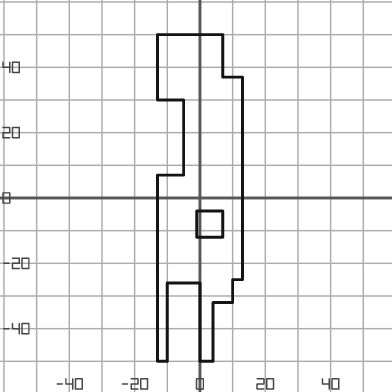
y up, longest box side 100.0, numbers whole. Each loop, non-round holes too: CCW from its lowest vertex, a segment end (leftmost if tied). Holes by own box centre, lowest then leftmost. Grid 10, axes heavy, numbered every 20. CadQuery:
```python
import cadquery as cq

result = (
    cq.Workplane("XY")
    .moveTo(-13.0, -50.0)
    .lineTo(-10.0, -50.0)
    .lineTo(-10.0, -26.0)
    .lineTo(0.0, -26.0)
    .lineTo(0.0, -50.0)
    .lineTo(4.0, -50.0)
    .lineTo(4.0, -32.0)
    .lineTo(10.0, -32.0)
    .lineTo(10.0, -25.0)
    .lineTo(13.0, -25.0)
    .lineTo(13.0, 37.0)
    .lineTo(7.0, 37.0)
    .lineTo(7.0, 50.0)
    .lineTo(-13.0, 50.0)
    .lineTo(-13.0, 30.0)
    .lineTo(-5.0, 30.0)
    .lineTo(-5.0, 7.0)
    .lineTo(-13.0, 7.0)
    .close()
    .moveTo(-1.0, -12.0)
    .lineTo(7.0, -12.0)
    .lineTo(7.0, -4.0)
    .lineTo(-1.0, -4.0)
    .close()
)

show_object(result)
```